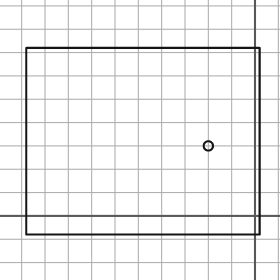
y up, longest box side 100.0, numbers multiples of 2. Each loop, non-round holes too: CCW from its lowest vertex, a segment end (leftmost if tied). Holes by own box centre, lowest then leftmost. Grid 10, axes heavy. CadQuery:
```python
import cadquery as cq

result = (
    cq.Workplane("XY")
    .moveTo(-98.0, -8.0)
    .lineTo(2.0, -8.0)
    .lineTo(2.0, 72.0)
    .lineTo(-98.0, 72.0)
    .close()
    .moveTo(-20.0, 30.0)
    .circle(2.0)
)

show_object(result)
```